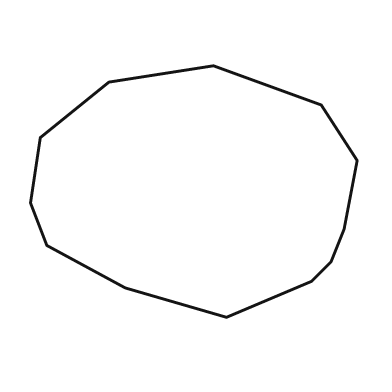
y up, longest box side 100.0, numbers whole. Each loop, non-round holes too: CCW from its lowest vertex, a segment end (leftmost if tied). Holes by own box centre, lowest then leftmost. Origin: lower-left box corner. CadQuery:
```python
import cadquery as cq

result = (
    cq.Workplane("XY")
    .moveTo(60.0, 0.0)
    .lineTo(86.0, 11.0)
    .lineTo(92.0, 17.0)
    .lineTo(96.0, 27.0)
    .lineTo(100.0, 48.0)
    .lineTo(89.0, 65.0)
    .lineTo(56.0, 77.0)
    .lineTo(24.0, 72.0)
    .lineTo(3.0, 55.0)
    .lineTo(0.0, 35.0)
    .lineTo(5.0, 22.0)
    .lineTo(29.0, 9.0)
    .close()
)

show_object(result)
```